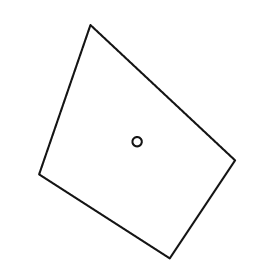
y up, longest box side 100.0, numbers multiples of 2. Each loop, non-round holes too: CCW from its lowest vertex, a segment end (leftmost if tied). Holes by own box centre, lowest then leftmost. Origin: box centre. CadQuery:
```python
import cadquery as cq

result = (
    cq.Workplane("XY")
    .moveTo(14.0, -50.0)
    .lineTo(42.0, -8.0)
    .lineTo(-20.0, 50.0)
    .lineTo(-42.0, -14.0)
    .close()
    .moveTo(0.0, 0.0)
    .circle(2.0)
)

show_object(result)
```